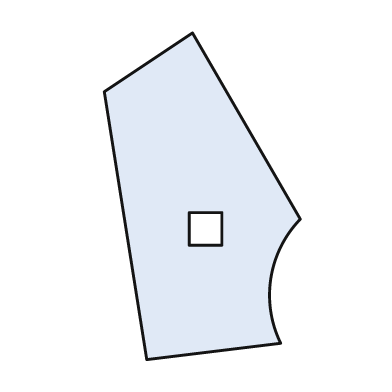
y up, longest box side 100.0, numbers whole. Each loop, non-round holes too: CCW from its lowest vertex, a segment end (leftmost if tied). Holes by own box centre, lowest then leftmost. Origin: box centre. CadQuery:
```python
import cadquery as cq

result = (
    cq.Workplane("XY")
    .moveTo(-17.0, -50.0)
    .lineTo(24.0, -45.0)
    .threePointArc((21.0, -25.0), (30.0, -7.0))
    .lineTo(-3.0, 50.0)
    .lineTo(-30.0, 32.0)
    .close()
    .moveTo(-4.0, -15.0)
    .lineTo(6.0, -15.0)
    .lineTo(6.0, -5.0)
    .lineTo(-4.0, -5.0)
    .close()
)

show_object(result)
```